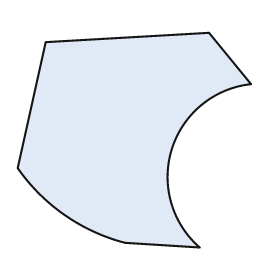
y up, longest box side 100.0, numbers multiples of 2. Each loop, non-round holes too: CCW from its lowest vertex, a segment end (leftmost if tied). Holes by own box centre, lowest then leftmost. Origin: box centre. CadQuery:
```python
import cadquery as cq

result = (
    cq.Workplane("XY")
    .moveTo(28.0, -46.0)
    .threePointArc((16.0, -4.0), (50.0, 24.0))
    .lineTo(32.0, 46.0)
    .lineTo(-38.0, 42.0)
    .lineTo(-50.0, -12.0)
    .threePointArc((-30.0, -32.0), (-4.0, -44.0))
    .close()
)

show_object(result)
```